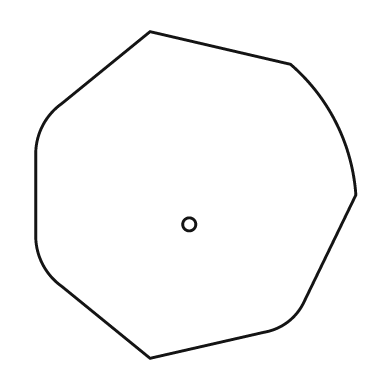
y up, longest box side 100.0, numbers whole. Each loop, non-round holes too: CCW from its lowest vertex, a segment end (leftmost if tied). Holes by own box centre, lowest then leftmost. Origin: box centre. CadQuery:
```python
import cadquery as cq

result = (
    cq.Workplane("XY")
    .moveTo(-14.0, -50.0)
    .lineTo(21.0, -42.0)
    .threePointArc((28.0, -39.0), (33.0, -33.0))
    .lineTo(49.0, 0.0)
    .threePointArc((43.0, 22.0), (29.0, 40.0))
    .lineTo(-14.0, 50.0)
    .lineTo(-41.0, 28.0)
    .threePointArc((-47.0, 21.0), (-49.0, 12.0))
    .lineTo(-49.0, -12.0)
    .threePointArc((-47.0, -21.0), (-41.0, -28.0))
    .close()
    .moveTo(-2.0, -9.0)
    .circle(2.0)
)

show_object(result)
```